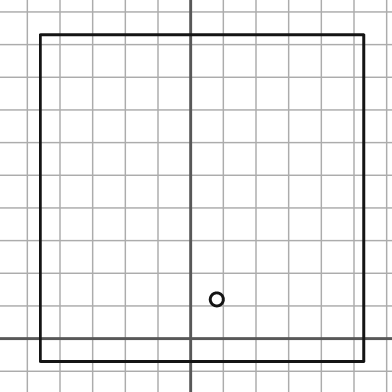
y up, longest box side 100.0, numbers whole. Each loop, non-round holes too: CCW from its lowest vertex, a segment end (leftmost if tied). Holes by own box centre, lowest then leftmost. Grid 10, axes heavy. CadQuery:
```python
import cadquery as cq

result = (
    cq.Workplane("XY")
    .moveTo(-46.0, -7.0)
    .lineTo(53.0, -7.0)
    .lineTo(53.0, 93.0)
    .lineTo(-46.0, 93.0)
    .close()
    .moveTo(8.0, 12.0)
    .circle(2.0)
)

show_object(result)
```